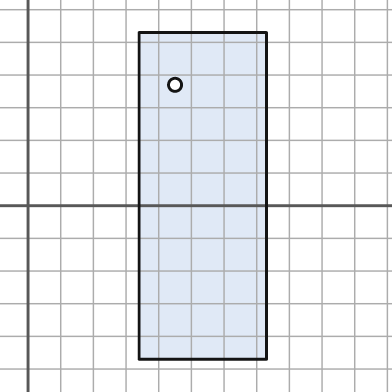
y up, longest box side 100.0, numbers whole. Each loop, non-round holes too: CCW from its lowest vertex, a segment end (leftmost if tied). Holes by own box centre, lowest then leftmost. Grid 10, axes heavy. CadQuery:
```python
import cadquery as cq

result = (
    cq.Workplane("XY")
    .moveTo(34.0, -47.0)
    .lineTo(73.0, -47.0)
    .lineTo(73.0, 53.0)
    .lineTo(34.0, 53.0)
    .close()
    .moveTo(45.0, 37.0)
    .circle(2.0)
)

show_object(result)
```